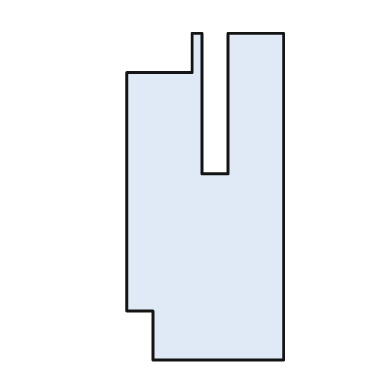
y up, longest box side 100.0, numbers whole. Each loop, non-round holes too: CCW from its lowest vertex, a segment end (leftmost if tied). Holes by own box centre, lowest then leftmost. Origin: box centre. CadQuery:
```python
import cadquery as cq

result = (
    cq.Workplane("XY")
    .moveTo(-16.0, -50.0)
    .lineTo(24.0, -50.0)
    .lineTo(24.0, 50.0)
    .lineTo(7.0, 50.0)
    .lineTo(7.0, 7.0)
    .lineTo(-1.0, 7.0)
    .lineTo(-1.0, 50.0)
    .lineTo(-4.0, 50.0)
    .lineTo(-4.0, 38.0)
    .lineTo(-24.0, 38.0)
    .lineTo(-24.0, -35.0)
    .lineTo(-16.0, -35.0)
    .close()
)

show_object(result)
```